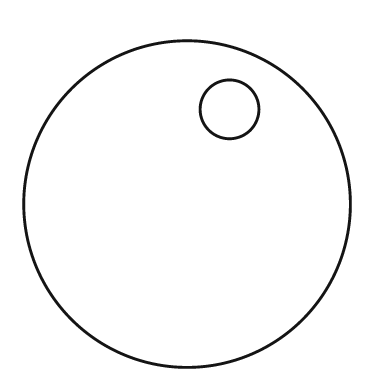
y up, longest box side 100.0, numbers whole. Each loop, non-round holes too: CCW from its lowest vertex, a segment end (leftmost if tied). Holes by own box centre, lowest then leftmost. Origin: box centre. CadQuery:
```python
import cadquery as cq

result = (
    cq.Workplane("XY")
    .moveTo(0.0, 0.0)
    .circle(50.0)
    .moveTo(13.0, 29.0)
    .circle(9.0)
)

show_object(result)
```